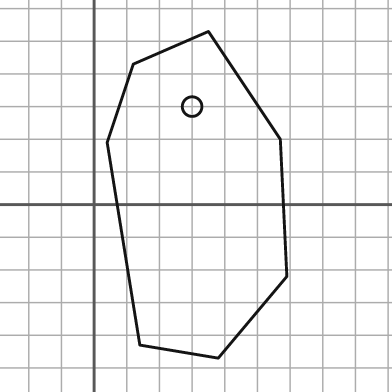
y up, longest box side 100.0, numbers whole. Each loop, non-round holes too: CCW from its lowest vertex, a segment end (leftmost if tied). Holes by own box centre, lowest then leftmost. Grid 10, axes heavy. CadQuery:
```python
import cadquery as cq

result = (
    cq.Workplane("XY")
    .moveTo(38.0, -47.0)
    .lineTo(59.0, -22.0)
    .lineTo(57.0, 20.0)
    .lineTo(35.0, 53.0)
    .lineTo(12.0, 43.0)
    .lineTo(4.0, 19.0)
    .lineTo(14.0, -43.0)
    .close()
    .moveTo(30.0, 30.0)
    .circle(3.0)
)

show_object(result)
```